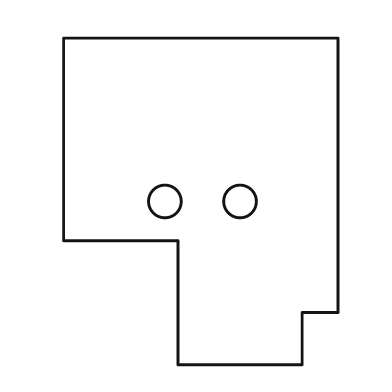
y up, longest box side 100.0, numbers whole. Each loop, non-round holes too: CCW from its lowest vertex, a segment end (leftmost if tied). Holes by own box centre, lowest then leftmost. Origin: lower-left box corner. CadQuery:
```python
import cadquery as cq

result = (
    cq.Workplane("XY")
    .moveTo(35.0, 0.0)
    .lineTo(73.0, 0.0)
    .lineTo(73.0, 16.0)
    .lineTo(84.0, 16.0)
    .lineTo(84.0, 100.0)
    .lineTo(0.0, 100.0)
    .lineTo(0.0, 38.0)
    .lineTo(35.0, 38.0)
    .close()
    .moveTo(31.0, 50.0)
    .circle(5.0)
    .moveTo(54.0, 50.0)
    .circle(5.0)
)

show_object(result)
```